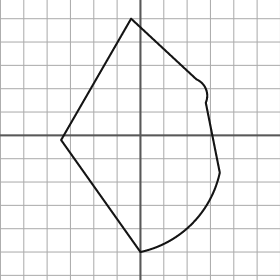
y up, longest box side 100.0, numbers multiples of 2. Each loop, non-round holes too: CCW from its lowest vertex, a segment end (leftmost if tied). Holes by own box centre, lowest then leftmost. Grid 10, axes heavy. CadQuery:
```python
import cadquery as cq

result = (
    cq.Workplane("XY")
    .moveTo(0.0, -50.0)
    .threePointArc((22.0, -38.0), (34.0, -16.0))
    .lineTo(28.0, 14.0)
    .threePointArc((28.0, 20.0), (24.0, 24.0))
    .lineTo(-4.0, 50.0)
    .lineTo(-34.0, -2.0)
    .close()
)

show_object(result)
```